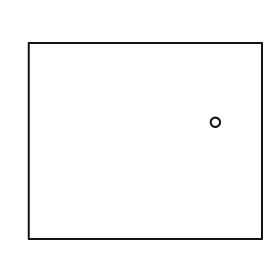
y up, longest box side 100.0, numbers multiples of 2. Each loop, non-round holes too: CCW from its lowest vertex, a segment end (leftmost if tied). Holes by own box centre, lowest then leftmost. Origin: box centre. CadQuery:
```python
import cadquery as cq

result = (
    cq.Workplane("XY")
    .moveTo(-50.0, -42.0)
    .lineTo(50.0, -42.0)
    .lineTo(50.0, 42.0)
    .lineTo(-50.0, 42.0)
    .close()
    .moveTo(30.0, 8.0)
    .circle(2.0)
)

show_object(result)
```